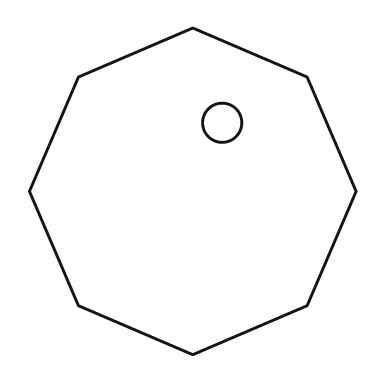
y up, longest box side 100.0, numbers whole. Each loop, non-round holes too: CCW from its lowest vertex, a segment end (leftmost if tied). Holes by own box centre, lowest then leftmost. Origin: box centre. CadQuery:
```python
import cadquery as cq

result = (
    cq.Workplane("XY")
    .moveTo(0.0, -50.0)
    .lineTo(35.0, -35.0)
    .lineTo(50.0, 0.0)
    .lineTo(35.0, 35.0)
    .lineTo(0.0, 50.0)
    .lineTo(-35.0, 35.0)
    .lineTo(-50.0, 0.0)
    .lineTo(-35.0, -35.0)
    .close()
    .moveTo(9.0, 21.0)
    .circle(6.0)
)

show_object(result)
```